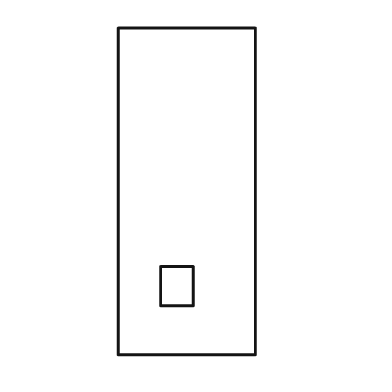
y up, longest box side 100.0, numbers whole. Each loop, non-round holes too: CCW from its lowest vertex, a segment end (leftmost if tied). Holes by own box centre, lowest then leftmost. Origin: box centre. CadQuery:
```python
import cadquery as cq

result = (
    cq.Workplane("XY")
    .moveTo(-21.0, -50.0)
    .lineTo(21.0, -50.0)
    .lineTo(21.0, 50.0)
    .lineTo(-21.0, 50.0)
    .close()
    .moveTo(-8.0, -35.0)
    .lineTo(2.0, -35.0)
    .lineTo(2.0, -23.0)
    .lineTo(-8.0, -23.0)
    .close()
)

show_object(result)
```